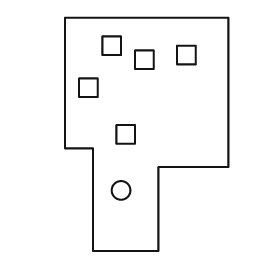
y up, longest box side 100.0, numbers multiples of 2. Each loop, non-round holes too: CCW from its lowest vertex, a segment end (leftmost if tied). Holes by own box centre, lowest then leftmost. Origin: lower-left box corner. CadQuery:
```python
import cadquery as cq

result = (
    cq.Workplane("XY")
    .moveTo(12.0, 0.0)
    .lineTo(40.0, 0.0)
    .lineTo(40.0, 36.0)
    .lineTo(70.0, 36.0)
    .lineTo(70.0, 100.0)
    .lineTo(0.0, 100.0)
    .lineTo(0.0, 44.0)
    .lineTo(12.0, 44.0)
    .close()
    .moveTo(24.0, 26.0)
    .circle(4.0)
    .moveTo(22.0, 46.0)
    .lineTo(30.0, 46.0)
    .lineTo(30.0, 54.0)
    .lineTo(22.0, 54.0)
    .close()
    .moveTo(6.0, 66.0)
    .lineTo(14.0, 66.0)
    .lineTo(14.0, 74.0)
    .lineTo(6.0, 74.0)
    .close()
    .moveTo(30.0, 78.0)
    .lineTo(38.0, 78.0)
    .lineTo(38.0, 86.0)
    .lineTo(30.0, 86.0)
    .close()
    .moveTo(48.0, 80.0)
    .lineTo(56.0, 80.0)
    .lineTo(56.0, 88.0)
    .lineTo(48.0, 88.0)
    .close()
    .moveTo(16.0, 84.0)
    .lineTo(24.0, 84.0)
    .lineTo(24.0, 92.0)
    .lineTo(16.0, 92.0)
    .close()
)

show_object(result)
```